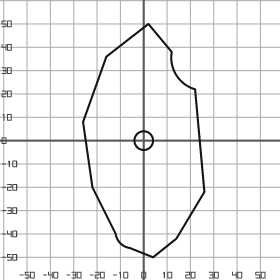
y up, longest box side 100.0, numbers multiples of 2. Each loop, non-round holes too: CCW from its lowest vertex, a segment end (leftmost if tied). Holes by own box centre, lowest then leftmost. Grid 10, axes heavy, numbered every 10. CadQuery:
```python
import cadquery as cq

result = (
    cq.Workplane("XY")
    .moveTo(4.0, -50.0)
    .lineTo(14.0, -42.0)
    .lineTo(26.0, -22.0)
    .lineTo(22.0, 22.0)
    .threePointArc((14.0, 28.0), (12.0, 38.0))
    .lineTo(2.0, 50.0)
    .lineTo(-16.0, 36.0)
    .lineTo(-26.0, 8.0)
    .lineTo(-22.0, -20.0)
    .lineTo(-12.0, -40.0)
    .threePointArc((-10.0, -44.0), (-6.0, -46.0))
    .close()
    .moveTo(0.0, 0.0)
    .circle(4.0)
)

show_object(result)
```